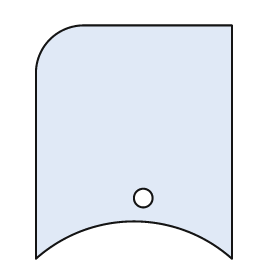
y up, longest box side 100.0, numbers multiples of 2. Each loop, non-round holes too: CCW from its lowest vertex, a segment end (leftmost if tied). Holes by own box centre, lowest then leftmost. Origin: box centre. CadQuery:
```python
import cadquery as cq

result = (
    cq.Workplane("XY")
    .moveTo(-42.0, -50.0)
    .threePointArc((0.0, -34.0), (42.0, -50.0))
    .lineTo(42.0, 50.0)
    .lineTo(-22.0, 50.0)
    .threePointArc((-36.0, 44.0), (-42.0, 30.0))
    .close()
    .moveTo(4.0, -24.0)
    .circle(4.0)
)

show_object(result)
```